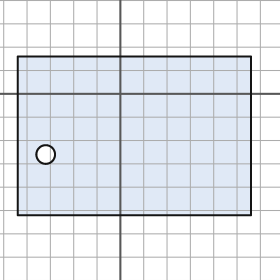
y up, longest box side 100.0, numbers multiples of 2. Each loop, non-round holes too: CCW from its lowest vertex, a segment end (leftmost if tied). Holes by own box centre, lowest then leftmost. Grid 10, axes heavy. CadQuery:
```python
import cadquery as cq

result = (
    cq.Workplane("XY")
    .moveTo(-44.0, -52.0)
    .lineTo(56.0, -52.0)
    .lineTo(56.0, 16.0)
    .lineTo(-44.0, 16.0)
    .close()
    .moveTo(-32.0, -26.0)
    .circle(4.0)
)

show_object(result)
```